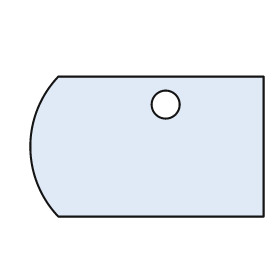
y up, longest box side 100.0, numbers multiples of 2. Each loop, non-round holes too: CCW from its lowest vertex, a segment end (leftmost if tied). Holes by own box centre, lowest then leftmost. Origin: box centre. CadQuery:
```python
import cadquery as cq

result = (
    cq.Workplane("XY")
    .moveTo(-38.0, -30.0)
    .lineTo(50.0, -30.0)
    .lineTo(50.0, 30.0)
    .lineTo(-38.0, 30.0)
    .threePointArc((-50.0, 0.0), (-38.0, -30.0))
    .close()
    .moveTo(8.0, 18.0)
    .circle(6.0)
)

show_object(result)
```